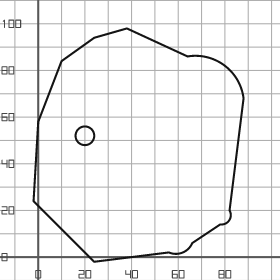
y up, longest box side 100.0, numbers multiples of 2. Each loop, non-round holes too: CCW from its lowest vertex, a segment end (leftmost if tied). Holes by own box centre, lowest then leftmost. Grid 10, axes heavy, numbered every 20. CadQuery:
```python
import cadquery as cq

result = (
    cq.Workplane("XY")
    .moveTo(24.0, -2.0)
    .lineTo(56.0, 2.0)
    .threePointArc((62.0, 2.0), (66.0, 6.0))
    .lineTo(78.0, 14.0)
    .threePointArc((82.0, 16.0), (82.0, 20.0))
    .lineTo(88.0, 68.0)
    .threePointArc((80.0, 82.0), (64.0, 86.0))
    .lineTo(38.0, 98.0)
    .lineTo(24.0, 94.0)
    .lineTo(10.0, 84.0)
    .lineTo(0.0, 58.0)
    .lineTo(-2.0, 24.0)
    .close()
    .moveTo(20.0, 52.0)
    .circle(4.0)
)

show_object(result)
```